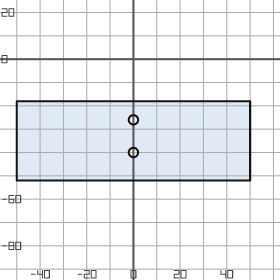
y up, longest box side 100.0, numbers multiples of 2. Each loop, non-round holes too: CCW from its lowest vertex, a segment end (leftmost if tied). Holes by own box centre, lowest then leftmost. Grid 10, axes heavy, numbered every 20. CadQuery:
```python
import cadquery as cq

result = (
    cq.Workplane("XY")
    .moveTo(-50.0, -52.0)
    .lineTo(50.0, -52.0)
    .lineTo(50.0, -18.0)
    .lineTo(-50.0, -18.0)
    .close()
    .moveTo(0.0, -40.0)
    .circle(2.0)
    .moveTo(0.0, -26.0)
    .circle(2.0)
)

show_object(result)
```